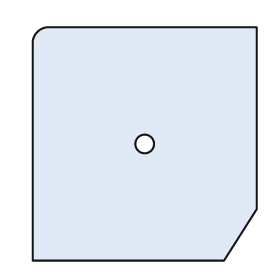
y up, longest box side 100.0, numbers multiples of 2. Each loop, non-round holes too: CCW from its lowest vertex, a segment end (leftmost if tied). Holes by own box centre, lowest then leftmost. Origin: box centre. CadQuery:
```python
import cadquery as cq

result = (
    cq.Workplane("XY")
    .moveTo(-48.0, -50.0)
    .lineTo(34.0, -50.0)
    .lineTo(48.0, -28.0)
    .lineTo(48.0, 50.0)
    .lineTo(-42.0, 50.0)
    .threePointArc((-46.0, 48.0), (-48.0, 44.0))
    .close()
    .moveTo(0.0, 0.0)
    .circle(4.0)
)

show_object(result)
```